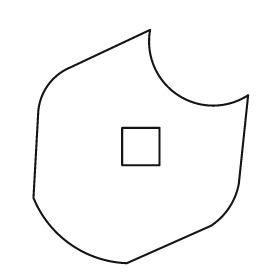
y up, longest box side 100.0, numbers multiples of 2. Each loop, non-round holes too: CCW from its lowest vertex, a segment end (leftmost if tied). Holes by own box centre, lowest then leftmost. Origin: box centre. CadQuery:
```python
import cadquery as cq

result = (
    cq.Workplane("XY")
    .moveTo(-6.0, -50.0)
    .lineTo(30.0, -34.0)
    .threePointArc((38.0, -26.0), (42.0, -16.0))
    .lineTo(46.0, 22.0)
    .threePointArc((16.0, 22.0), (4.0, 50.0))
    .lineTo(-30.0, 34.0)
    .threePointArc((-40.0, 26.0), (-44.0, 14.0))
    .lineTo(-46.0, -22.0)
    .threePointArc((-30.0, -42.0), (-6.0, -50.0))
    .close()
    .moveTo(-8.0, -8.0)
    .lineTo(8.0, -8.0)
    .lineTo(8.0, 8.0)
    .lineTo(-8.0, 8.0)
    .close()
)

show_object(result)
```